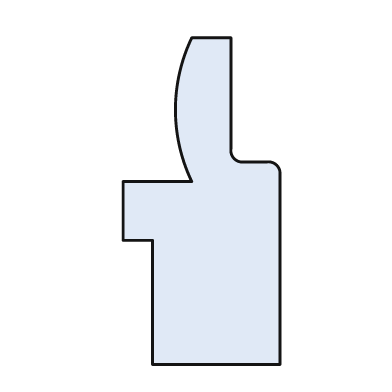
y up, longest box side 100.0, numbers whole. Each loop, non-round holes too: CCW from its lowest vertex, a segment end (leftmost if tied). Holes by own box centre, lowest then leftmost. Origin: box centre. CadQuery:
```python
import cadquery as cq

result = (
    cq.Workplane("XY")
    .moveTo(-15.0, -50.0)
    .lineTo(24.0, -50.0)
    .lineTo(24.0, 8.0)
    .threePointArc((23.0, 11.0), (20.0, 12.0))
    .lineTo(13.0, 12.0)
    .threePointArc((10.0, 13.0), (9.0, 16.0))
    .lineTo(9.0, 50.0)
    .lineTo(-3.0, 50.0)
    .threePointArc((-8.0, 28.0), (-3.0, 6.0))
    .lineTo(-24.0, 6.0)
    .lineTo(-24.0, -12.0)
    .lineTo(-15.0, -12.0)
    .close()
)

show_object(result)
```